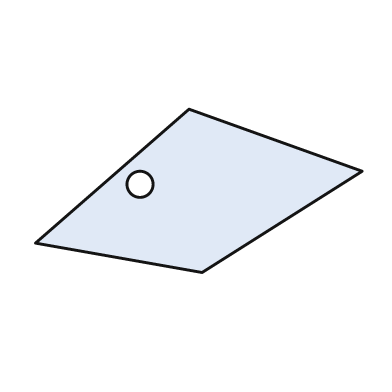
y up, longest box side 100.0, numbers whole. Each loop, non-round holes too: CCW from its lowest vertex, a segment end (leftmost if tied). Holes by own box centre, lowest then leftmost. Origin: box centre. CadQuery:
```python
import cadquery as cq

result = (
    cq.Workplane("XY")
    .moveTo(1.0, -25.0)
    .lineTo(50.0, 6.0)
    .lineTo(-3.0, 25.0)
    .lineTo(-50.0, -16.0)
    .close()
    .moveTo(-18.0, 2.0)
    .circle(4.0)
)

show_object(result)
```